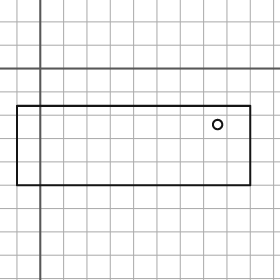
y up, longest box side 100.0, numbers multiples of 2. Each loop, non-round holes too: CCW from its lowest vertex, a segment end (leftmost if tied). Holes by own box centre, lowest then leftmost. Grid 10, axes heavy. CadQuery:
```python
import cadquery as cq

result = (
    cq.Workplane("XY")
    .moveTo(-10.0, -50.0)
    .lineTo(90.0, -50.0)
    .lineTo(90.0, -16.0)
    .lineTo(-10.0, -16.0)
    .close()
    .moveTo(76.0, -24.0)
    .circle(2.0)
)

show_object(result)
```